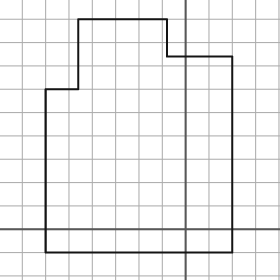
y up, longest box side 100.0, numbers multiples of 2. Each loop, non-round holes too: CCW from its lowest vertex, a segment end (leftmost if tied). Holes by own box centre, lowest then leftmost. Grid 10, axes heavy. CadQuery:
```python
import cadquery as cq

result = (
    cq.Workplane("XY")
    .moveTo(-60.0, -10.0)
    .lineTo(20.0, -10.0)
    .lineTo(20.0, 74.0)
    .lineTo(-8.0, 74.0)
    .lineTo(-8.0, 90.0)
    .lineTo(-46.0, 90.0)
    .lineTo(-46.0, 60.0)
    .lineTo(-60.0, 60.0)
    .close()
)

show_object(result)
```